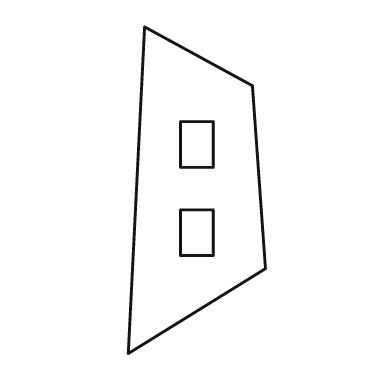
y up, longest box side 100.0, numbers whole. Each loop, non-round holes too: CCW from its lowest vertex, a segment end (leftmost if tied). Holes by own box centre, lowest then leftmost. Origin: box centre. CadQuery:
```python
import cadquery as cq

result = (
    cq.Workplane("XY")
    .moveTo(-21.0, -50.0)
    .lineTo(21.0, -24.0)
    .lineTo(17.0, 32.0)
    .lineTo(-16.0, 50.0)
    .close()
    .moveTo(-5.0, -20.0)
    .lineTo(5.0, -20.0)
    .lineTo(5.0, -6.0)
    .lineTo(-5.0, -6.0)
    .close()
    .moveTo(-5.0, 7.0)
    .lineTo(5.0, 7.0)
    .lineTo(5.0, 21.0)
    .lineTo(-5.0, 21.0)
    .close()
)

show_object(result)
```